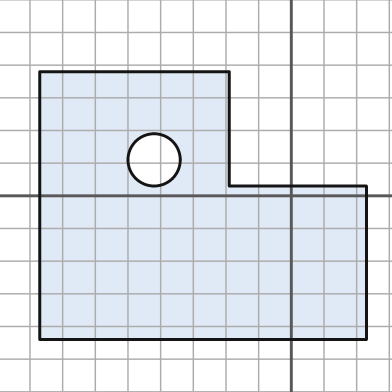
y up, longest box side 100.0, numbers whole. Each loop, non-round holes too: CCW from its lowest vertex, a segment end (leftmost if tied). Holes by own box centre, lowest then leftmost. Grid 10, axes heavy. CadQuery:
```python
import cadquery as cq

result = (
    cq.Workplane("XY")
    .moveTo(-77.0, -44.0)
    .lineTo(23.0, -44.0)
    .lineTo(23.0, 3.0)
    .lineTo(-19.0, 3.0)
    .lineTo(-19.0, 38.0)
    .lineTo(-77.0, 38.0)
    .close()
    .moveTo(-42.0, 11.0)
    .circle(8.0)
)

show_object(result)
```